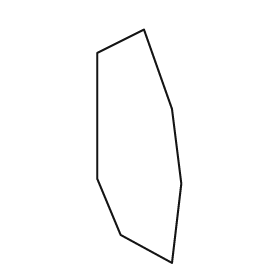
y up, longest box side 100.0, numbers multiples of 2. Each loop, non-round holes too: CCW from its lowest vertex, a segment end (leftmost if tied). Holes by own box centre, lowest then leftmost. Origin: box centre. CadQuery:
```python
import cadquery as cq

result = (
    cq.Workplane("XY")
    .moveTo(14.0, -50.0)
    .lineTo(18.0, -16.0)
    .lineTo(14.0, 16.0)
    .lineTo(2.0, 50.0)
    .lineTo(-18.0, 40.0)
    .lineTo(-18.0, -14.0)
    .lineTo(-8.0, -38.0)
    .close()
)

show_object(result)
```